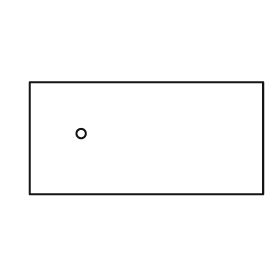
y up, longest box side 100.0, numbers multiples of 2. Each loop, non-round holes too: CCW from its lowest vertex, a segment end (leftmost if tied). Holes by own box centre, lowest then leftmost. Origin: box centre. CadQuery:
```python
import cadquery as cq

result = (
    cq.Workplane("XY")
    .moveTo(-50.0, -24.0)
    .lineTo(50.0, -24.0)
    .lineTo(50.0, 24.0)
    .lineTo(-50.0, 24.0)
    .close()
    .moveTo(-28.0, 2.0)
    .circle(2.0)
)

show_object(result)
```